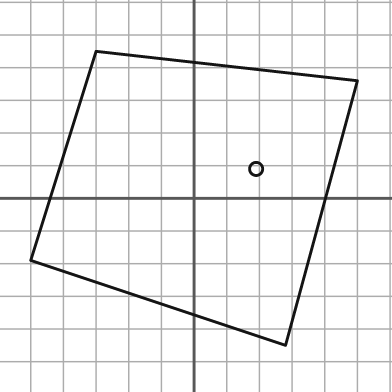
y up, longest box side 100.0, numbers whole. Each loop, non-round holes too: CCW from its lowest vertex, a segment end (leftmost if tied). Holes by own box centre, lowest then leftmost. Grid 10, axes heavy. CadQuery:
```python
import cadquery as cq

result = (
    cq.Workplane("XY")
    .moveTo(28.0, -45.0)
    .lineTo(50.0, 36.0)
    .lineTo(-30.0, 45.0)
    .lineTo(-50.0, -19.0)
    .close()
    .moveTo(19.0, 9.0)
    .circle(2.0)
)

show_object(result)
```